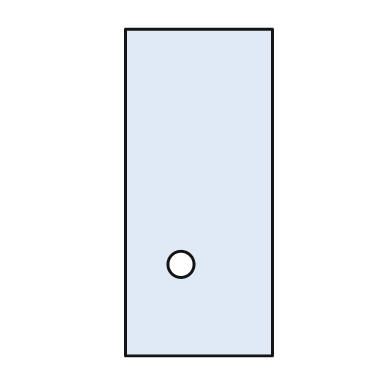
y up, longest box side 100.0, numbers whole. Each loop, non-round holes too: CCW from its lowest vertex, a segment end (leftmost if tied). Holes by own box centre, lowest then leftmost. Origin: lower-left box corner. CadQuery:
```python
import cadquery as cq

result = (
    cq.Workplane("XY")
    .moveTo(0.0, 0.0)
    .lineTo(45.0, 0.0)
    .lineTo(45.0, 100.0)
    .lineTo(0.0, 100.0)
    .close()
    .moveTo(17.0, 28.0)
    .circle(4.0)
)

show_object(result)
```